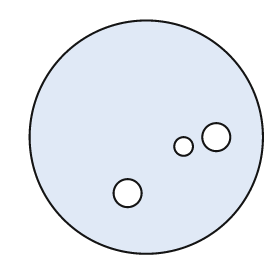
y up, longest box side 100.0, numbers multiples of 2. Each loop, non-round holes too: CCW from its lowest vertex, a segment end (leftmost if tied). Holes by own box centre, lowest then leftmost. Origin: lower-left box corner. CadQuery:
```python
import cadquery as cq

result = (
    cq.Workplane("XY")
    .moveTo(50.0, 50.0)
    .circle(50.0)
    .moveTo(42.0, 26.0)
    .circle(6.0)
    .moveTo(66.0, 46.0)
    .circle(4.0)
    .moveTo(80.0, 50.0)
    .circle(6.0)
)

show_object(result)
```